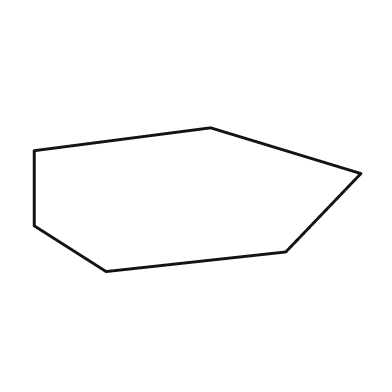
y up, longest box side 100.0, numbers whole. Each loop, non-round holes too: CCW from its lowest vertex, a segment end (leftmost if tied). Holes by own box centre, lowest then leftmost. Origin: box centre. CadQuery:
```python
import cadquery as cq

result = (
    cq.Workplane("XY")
    .moveTo(-28.0, -22.0)
    .lineTo(27.0, -16.0)
    .lineTo(50.0, 8.0)
    .lineTo(4.0, 22.0)
    .lineTo(-50.0, 15.0)
    .lineTo(-50.0, -8.0)
    .close()
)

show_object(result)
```